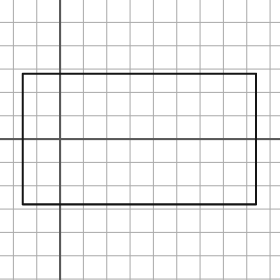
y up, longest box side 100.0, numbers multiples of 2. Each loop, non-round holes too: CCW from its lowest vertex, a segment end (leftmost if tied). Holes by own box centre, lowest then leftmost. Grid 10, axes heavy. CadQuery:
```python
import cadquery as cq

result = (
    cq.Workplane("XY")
    .moveTo(-16.0, -28.0)
    .lineTo(84.0, -28.0)
    .lineTo(84.0, 28.0)
    .lineTo(-16.0, 28.0)
    .close()
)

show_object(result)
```